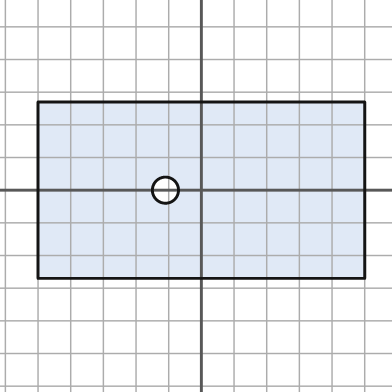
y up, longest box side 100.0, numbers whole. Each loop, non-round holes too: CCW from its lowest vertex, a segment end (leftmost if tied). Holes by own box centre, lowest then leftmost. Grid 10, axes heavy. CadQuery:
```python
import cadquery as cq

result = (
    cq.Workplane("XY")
    .moveTo(-50.0, -27.0)
    .lineTo(50.0, -27.0)
    .lineTo(50.0, 27.0)
    .lineTo(-50.0, 27.0)
    .close()
    .moveTo(-11.0, 0.0)
    .circle(4.0)
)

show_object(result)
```